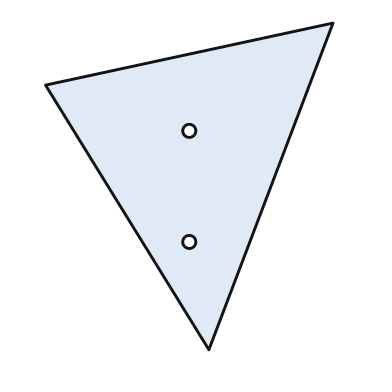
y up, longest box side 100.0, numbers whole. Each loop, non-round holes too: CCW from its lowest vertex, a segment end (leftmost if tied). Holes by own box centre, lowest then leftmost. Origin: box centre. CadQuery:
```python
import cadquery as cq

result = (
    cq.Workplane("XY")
    .moveTo(6.0, -50.0)
    .lineTo(44.0, 50.0)
    .lineTo(-44.0, 31.0)
    .close()
    .moveTo(0.0, -17.0)
    .circle(2.0)
    .moveTo(0.0, 17.0)
    .circle(2.0)
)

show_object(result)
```